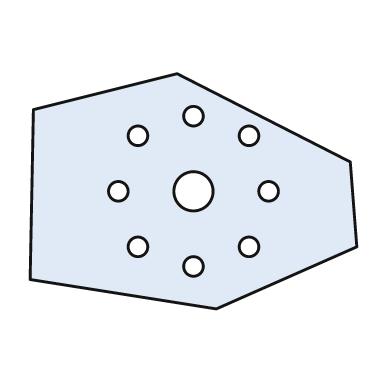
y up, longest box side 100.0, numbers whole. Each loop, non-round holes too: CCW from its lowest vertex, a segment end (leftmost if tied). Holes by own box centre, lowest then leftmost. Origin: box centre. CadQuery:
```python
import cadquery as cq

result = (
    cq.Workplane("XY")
    .moveTo(7.0, -36.0)
    .lineTo(50.0, -17.0)
    .lineTo(48.0, 9.0)
    .lineTo(-5.0, 36.0)
    .lineTo(-49.0, 25.0)
    .lineTo(-50.0, -27.0)
    .close()
    .moveTo(0.0, -23.0)
    .circle(3.0)
    .moveTo(-17.0, -17.0)
    .circle(3.0)
    .moveTo(17.0, -17.0)
    .circle(3.0)
    .moveTo(-23.0, 0.0)
    .circle(3.0)
    .moveTo(0.0, 0.0)
    .circle(6.0)
    .moveTo(23.0, 0.0)
    .circle(3.0)
    .moveTo(-17.0, 17.0)
    .circle(3.0)
    .moveTo(17.0, 17.0)
    .circle(3.0)
    .moveTo(0.0, 23.0)
    .circle(3.0)
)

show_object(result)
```